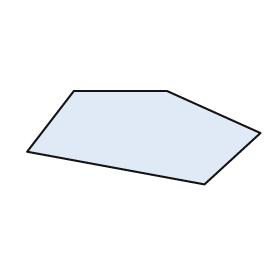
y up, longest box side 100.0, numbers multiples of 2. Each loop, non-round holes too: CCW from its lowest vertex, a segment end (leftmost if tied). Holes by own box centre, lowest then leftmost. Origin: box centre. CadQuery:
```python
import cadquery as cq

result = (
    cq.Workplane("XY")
    .moveTo(26.0, -20.0)
    .lineTo(50.0, 2.0)
    .lineTo(10.0, 20.0)
    .lineTo(-30.0, 20.0)
    .lineTo(-50.0, -6.0)
    .close()
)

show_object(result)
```